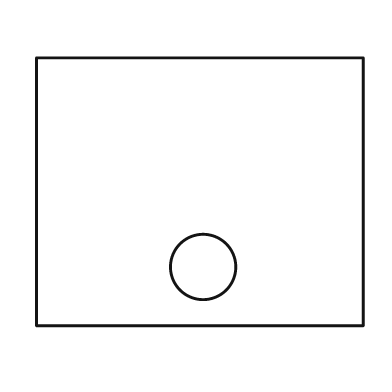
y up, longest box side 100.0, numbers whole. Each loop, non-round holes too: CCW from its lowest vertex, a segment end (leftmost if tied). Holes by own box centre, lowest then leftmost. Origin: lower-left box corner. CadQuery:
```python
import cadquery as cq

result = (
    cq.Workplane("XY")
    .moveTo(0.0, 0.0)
    .lineTo(100.0, 0.0)
    .lineTo(100.0, 82.0)
    .lineTo(0.0, 82.0)
    .close()
    .moveTo(51.0, 18.0)
    .circle(10.0)
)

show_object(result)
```